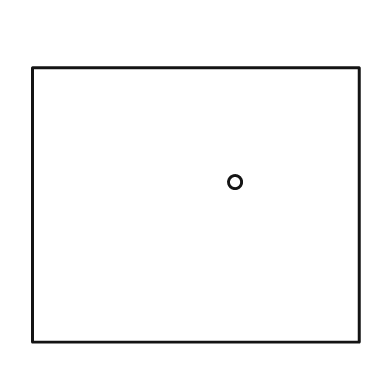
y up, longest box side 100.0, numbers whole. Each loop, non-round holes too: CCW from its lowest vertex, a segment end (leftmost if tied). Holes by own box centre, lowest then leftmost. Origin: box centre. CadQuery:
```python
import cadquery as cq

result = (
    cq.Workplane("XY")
    .moveTo(-50.0, -42.0)
    .lineTo(50.0, -42.0)
    .lineTo(50.0, 42.0)
    .lineTo(-50.0, 42.0)
    .close()
    .moveTo(12.0, 7.0)
    .circle(2.0)
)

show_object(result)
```